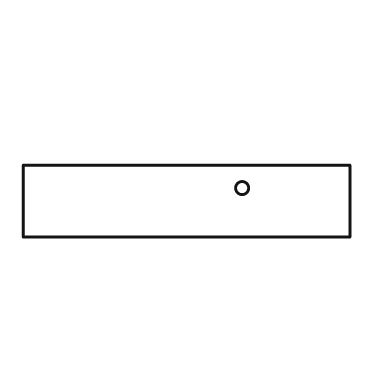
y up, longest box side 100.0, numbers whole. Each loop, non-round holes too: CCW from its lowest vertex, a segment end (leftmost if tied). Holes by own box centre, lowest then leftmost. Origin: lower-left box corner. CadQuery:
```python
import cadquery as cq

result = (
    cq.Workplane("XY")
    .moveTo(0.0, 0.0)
    .lineTo(100.0, 0.0)
    .lineTo(100.0, 22.0)
    .lineTo(0.0, 22.0)
    .close()
    .moveTo(67.0, 15.0)
    .circle(2.0)
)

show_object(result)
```